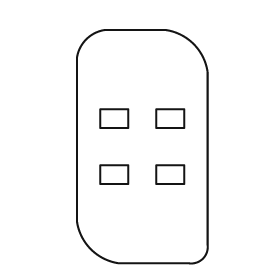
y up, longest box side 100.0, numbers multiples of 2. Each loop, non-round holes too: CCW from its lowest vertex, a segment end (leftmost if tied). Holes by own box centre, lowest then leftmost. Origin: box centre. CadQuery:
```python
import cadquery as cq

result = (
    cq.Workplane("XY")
    .moveTo(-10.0, -50.0)
    .lineTo(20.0, -50.0)
    .threePointArc((26.0, -48.0), (28.0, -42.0))
    .lineTo(28.0, 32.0)
    .threePointArc((22.0, 44.0), (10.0, 50.0))
    .lineTo(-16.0, 50.0)
    .threePointArc((-24.0, 46.0), (-28.0, 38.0))
    .lineTo(-28.0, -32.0)
    .threePointArc((-22.0, -44.0), (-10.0, -50.0))
    .close()
    .moveTo(-18.0, -16.0)
    .lineTo(-6.0, -16.0)
    .lineTo(-6.0, -8.0)
    .lineTo(-18.0, -8.0)
    .close()
    .moveTo(6.0, -16.0)
    .lineTo(18.0, -16.0)
    .lineTo(18.0, -8.0)
    .lineTo(6.0, -8.0)
    .close()
    .moveTo(-18.0, 8.0)
    .lineTo(-6.0, 8.0)
    .lineTo(-6.0, 16.0)
    .lineTo(-18.0, 16.0)
    .close()
    .moveTo(6.0, 8.0)
    .lineTo(18.0, 8.0)
    .lineTo(18.0, 16.0)
    .lineTo(6.0, 16.0)
    .close()
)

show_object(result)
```